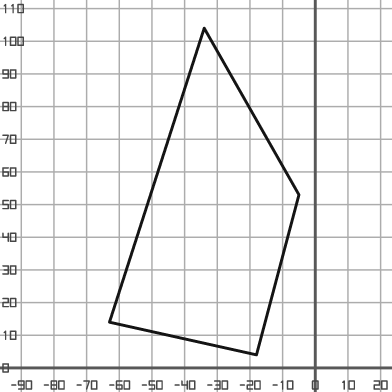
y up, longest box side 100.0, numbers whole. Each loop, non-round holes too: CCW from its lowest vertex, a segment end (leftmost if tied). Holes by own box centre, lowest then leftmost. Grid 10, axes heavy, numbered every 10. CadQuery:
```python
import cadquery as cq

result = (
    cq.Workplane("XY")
    .moveTo(-18.0, 4.0)
    .lineTo(-5.0, 53.0)
    .lineTo(-34.0, 104.0)
    .lineTo(-63.0, 14.0)
    .close()
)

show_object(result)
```